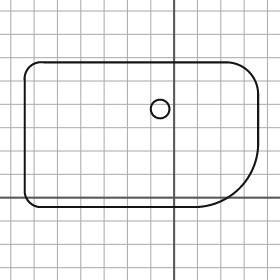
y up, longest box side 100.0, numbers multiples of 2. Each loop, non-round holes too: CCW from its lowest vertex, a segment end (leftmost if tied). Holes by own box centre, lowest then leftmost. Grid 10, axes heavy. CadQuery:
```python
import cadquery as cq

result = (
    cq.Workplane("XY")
    .moveTo(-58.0, -4.0)
    .lineTo(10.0, -4.0)
    .threePointArc((28.0, 4.0), (36.0, 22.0))
    .lineTo(36.0, 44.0)
    .threePointArc((32.0, 54.0), (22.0, 58.0))
    .lineTo(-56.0, 58.0)
    .threePointArc((-62.0, 56.0), (-64.0, 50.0))
    .lineTo(-64.0, 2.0)
    .threePointArc((-62.0, -2.0), (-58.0, -4.0))
    .close()
    .moveTo(-6.0, 38.0)
    .circle(4.0)
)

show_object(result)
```